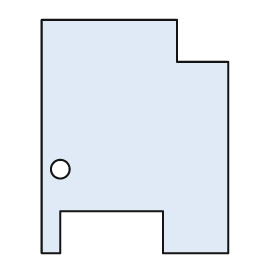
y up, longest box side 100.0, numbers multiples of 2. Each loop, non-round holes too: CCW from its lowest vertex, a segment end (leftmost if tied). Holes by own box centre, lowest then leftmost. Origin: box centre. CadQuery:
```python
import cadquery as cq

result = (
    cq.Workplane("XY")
    .moveTo(-40.0, -50.0)
    .lineTo(-32.0, -50.0)
    .lineTo(-32.0, -32.0)
    .lineTo(12.0, -32.0)
    .lineTo(12.0, -50.0)
    .lineTo(40.0, -50.0)
    .lineTo(40.0, 32.0)
    .lineTo(18.0, 32.0)
    .lineTo(18.0, 50.0)
    .lineTo(-40.0, 50.0)
    .close()
    .moveTo(-32.0, -14.0)
    .circle(4.0)
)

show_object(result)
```